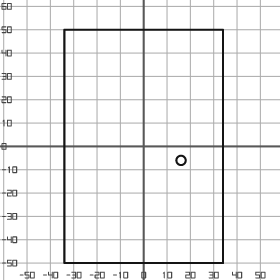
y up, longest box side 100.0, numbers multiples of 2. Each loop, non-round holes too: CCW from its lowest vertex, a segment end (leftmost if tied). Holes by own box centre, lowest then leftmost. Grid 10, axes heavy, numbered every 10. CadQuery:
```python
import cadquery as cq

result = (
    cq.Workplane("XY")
    .moveTo(-34.0, -50.0)
    .lineTo(34.0, -50.0)
    .lineTo(34.0, 50.0)
    .lineTo(-34.0, 50.0)
    .close()
    .moveTo(16.0, -6.0)
    .circle(2.0)
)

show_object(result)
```